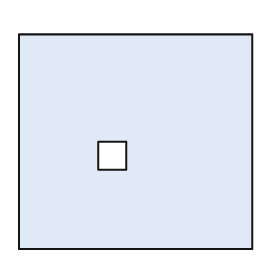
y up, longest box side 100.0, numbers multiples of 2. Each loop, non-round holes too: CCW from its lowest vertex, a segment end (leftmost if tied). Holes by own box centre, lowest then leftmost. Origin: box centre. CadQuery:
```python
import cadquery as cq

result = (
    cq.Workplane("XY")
    .moveTo(-50.0, -46.0)
    .lineTo(50.0, -46.0)
    .lineTo(50.0, 46.0)
    .lineTo(-50.0, 46.0)
    .close()
    .moveTo(-16.0, -12.0)
    .lineTo(-4.0, -12.0)
    .lineTo(-4.0, 0.0)
    .lineTo(-16.0, 0.0)
    .close()
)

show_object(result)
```